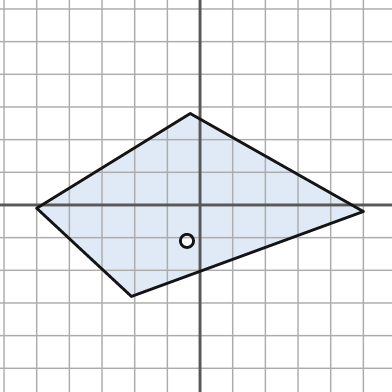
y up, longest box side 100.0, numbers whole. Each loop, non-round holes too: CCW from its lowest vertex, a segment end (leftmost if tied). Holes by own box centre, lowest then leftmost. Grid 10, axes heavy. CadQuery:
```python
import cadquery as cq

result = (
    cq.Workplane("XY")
    .moveTo(-21.0, -28.0)
    .lineTo(50.0, -2.0)
    .lineTo(-3.0, 28.0)
    .lineTo(-50.0, -1.0)
    .close()
    .moveTo(-4.0, -11.0)
    .circle(2.0)
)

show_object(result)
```